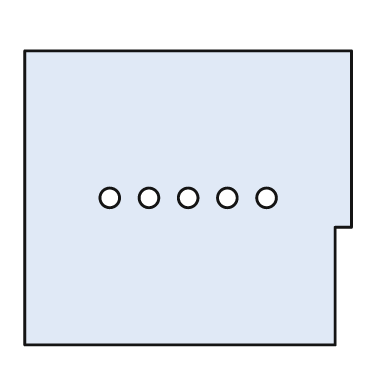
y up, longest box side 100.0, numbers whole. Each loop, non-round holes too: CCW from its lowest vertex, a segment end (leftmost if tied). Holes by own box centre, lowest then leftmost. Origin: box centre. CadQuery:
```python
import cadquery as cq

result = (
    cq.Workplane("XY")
    .moveTo(-50.0, -45.0)
    .lineTo(45.0, -45.0)
    .lineTo(45.0, -9.0)
    .lineTo(50.0, -9.0)
    .lineTo(50.0, 45.0)
    .lineTo(-50.0, 45.0)
    .close()
    .moveTo(-24.0, 0.0)
    .circle(3.0)
    .moveTo(-12.0, 0.0)
    .circle(3.0)
    .moveTo(0.0, 0.0)
    .circle(3.0)
    .moveTo(12.0, 0.0)
    .circle(3.0)
    .moveTo(24.0, 0.0)
    .circle(3.0)
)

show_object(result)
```